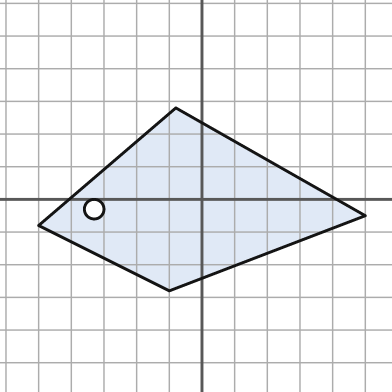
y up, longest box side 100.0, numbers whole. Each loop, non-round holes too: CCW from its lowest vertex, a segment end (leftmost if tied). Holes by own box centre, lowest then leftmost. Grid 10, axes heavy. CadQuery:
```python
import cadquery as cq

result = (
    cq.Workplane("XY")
    .moveTo(-10.0, -28.0)
    .lineTo(50.0, -5.0)
    .lineTo(-8.0, 28.0)
    .lineTo(-50.0, -8.0)
    .close()
    .moveTo(-33.0, -3.0)
    .circle(3.0)
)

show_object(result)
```